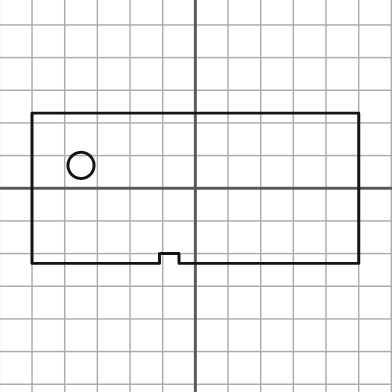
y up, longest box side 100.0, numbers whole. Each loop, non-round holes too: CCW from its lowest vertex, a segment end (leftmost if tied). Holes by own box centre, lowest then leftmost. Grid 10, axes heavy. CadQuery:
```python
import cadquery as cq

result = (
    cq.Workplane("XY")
    .moveTo(-50.0, -23.0)
    .lineTo(-11.0, -23.0)
    .lineTo(-11.0, -20.0)
    .lineTo(-5.0, -20.0)
    .lineTo(-5.0, -23.0)
    .lineTo(50.0, -23.0)
    .lineTo(50.0, 23.0)
    .lineTo(-50.0, 23.0)
    .close()
    .moveTo(-35.0, 7.0)
    .circle(4.0)
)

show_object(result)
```